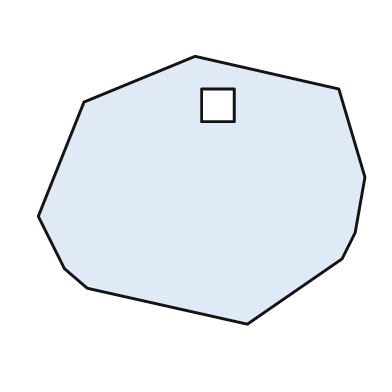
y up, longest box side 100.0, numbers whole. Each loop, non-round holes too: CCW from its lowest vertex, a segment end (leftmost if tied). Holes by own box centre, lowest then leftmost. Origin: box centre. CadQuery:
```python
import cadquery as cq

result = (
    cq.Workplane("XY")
    .moveTo(14.0, -41.0)
    .lineTo(43.0, -21.0)
    .lineTo(47.0, -13.0)
    .lineTo(50.0, 4.0)
    .lineTo(42.0, 31.0)
    .lineTo(-2.0, 41.0)
    .lineTo(-36.0, 27.0)
    .lineTo(-50.0, -8.0)
    .lineTo(-42.0, -24.0)
    .lineTo(-35.0, -30.0)
    .close()
    .moveTo(0.0, 21.0)
    .lineTo(10.0, 21.0)
    .lineTo(10.0, 31.0)
    .lineTo(0.0, 31.0)
    .close()
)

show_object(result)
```